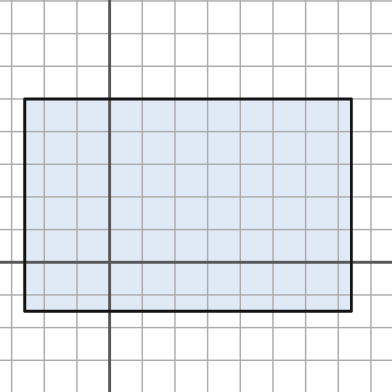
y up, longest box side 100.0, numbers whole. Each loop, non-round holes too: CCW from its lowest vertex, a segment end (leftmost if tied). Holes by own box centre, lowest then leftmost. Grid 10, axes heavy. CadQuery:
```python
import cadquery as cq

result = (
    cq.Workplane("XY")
    .moveTo(-26.0, -15.0)
    .lineTo(74.0, -15.0)
    .lineTo(74.0, 50.0)
    .lineTo(-26.0, 50.0)
    .close()
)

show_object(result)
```